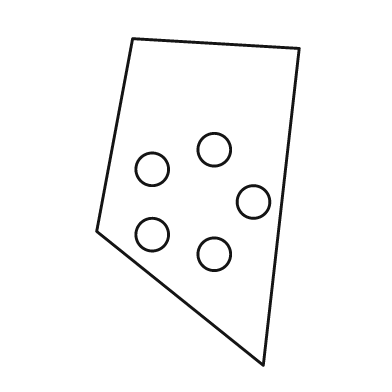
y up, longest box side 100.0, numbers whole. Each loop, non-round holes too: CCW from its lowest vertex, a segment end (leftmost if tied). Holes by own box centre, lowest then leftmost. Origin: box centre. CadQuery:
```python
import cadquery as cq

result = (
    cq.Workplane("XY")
    .moveTo(20.0, -50.0)
    .lineTo(31.0, 47.0)
    .lineTo(-20.0, 50.0)
    .lineTo(-31.0, -9.0)
    .close()
    .moveTo(5.0, -16.0)
    .circle(5.0)
    .moveTo(-14.0, -10.0)
    .circle(5.0)
    .moveTo(17.0, 0.0)
    .circle(5.0)
    .moveTo(-14.0, 10.0)
    .circle(5.0)
    .moveTo(5.0, 16.0)
    .circle(5.0)
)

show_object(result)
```